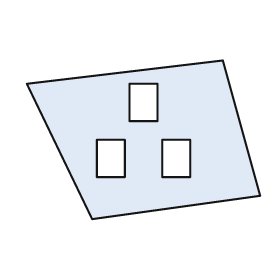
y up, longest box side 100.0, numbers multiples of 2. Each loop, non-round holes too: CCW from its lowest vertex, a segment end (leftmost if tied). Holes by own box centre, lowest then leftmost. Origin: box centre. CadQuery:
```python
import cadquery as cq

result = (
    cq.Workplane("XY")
    .moveTo(-22.0, -34.0)
    .lineTo(50.0, -24.0)
    .lineTo(34.0, 34.0)
    .lineTo(-50.0, 24.0)
    .close()
    .moveTo(-20.0, -16.0)
    .lineTo(-8.0, -16.0)
    .lineTo(-8.0, 0.0)
    .lineTo(-20.0, 0.0)
    .close()
    .moveTo(8.0, -16.0)
    .lineTo(20.0, -16.0)
    .lineTo(20.0, 0.0)
    .lineTo(8.0, 0.0)
    .close()
    .moveTo(-6.0, 8.0)
    .lineTo(6.0, 8.0)
    .lineTo(6.0, 24.0)
    .lineTo(-6.0, 24.0)
    .close()
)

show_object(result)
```